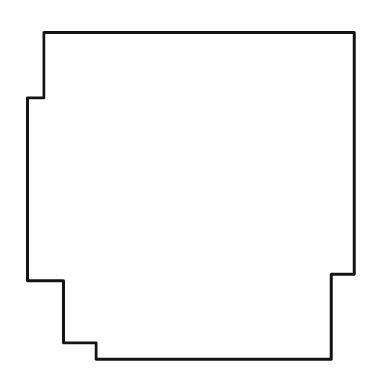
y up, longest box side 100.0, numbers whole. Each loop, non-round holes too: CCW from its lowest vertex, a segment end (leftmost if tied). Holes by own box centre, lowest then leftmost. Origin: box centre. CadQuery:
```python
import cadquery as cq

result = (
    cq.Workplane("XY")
    .moveTo(-29.0, -50.0)
    .lineTo(43.0, -50.0)
    .lineTo(43.0, -24.0)
    .lineTo(50.0, -24.0)
    .lineTo(50.0, 50.0)
    .lineTo(-45.0, 50.0)
    .lineTo(-45.0, 30.0)
    .lineTo(-50.0, 30.0)
    .lineTo(-50.0, -26.0)
    .lineTo(-39.0, -26.0)
    .lineTo(-39.0, -45.0)
    .lineTo(-29.0, -45.0)
    .close()
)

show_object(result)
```